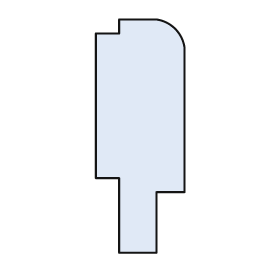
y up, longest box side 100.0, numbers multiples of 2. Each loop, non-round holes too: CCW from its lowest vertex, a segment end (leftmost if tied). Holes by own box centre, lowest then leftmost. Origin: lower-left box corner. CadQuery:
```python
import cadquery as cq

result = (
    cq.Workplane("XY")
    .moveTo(10.0, 0.0)
    .lineTo(26.0, 0.0)
    .lineTo(26.0, 26.0)
    .lineTo(38.0, 26.0)
    .lineTo(38.0, 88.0)
    .threePointArc((34.0, 96.0), (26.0, 100.0))
    .lineTo(10.0, 100.0)
    .lineTo(10.0, 94.0)
    .lineTo(0.0, 94.0)
    .lineTo(0.0, 32.0)
    .lineTo(10.0, 32.0)
    .close()
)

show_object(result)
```